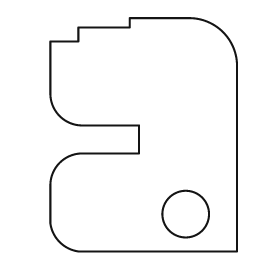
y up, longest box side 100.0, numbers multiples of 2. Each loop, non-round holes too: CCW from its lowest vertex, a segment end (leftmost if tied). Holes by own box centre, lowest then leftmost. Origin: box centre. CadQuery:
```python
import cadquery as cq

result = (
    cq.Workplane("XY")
    .moveTo(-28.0, -50.0)
    .lineTo(40.0, -50.0)
    .lineTo(40.0, 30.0)
    .threePointArc((34.0, 44.0), (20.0, 50.0))
    .lineTo(-6.0, 50.0)
    .lineTo(-6.0, 46.0)
    .lineTo(-28.0, 46.0)
    .lineTo(-28.0, 40.0)
    .lineTo(-40.0, 40.0)
    .lineTo(-40.0, 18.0)
    .threePointArc((-36.0, 8.0), (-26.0, 4.0))
    .lineTo(-2.0, 4.0)
    .lineTo(-2.0, -8.0)
    .lineTo(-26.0, -8.0)
    .threePointArc((-36.0, -12.0), (-40.0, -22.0))
    .lineTo(-40.0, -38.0)
    .threePointArc((-36.0, -46.0), (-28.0, -50.0))
    .close()
    .moveTo(18.0, -34.0)
    .circle(10.0)
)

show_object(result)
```